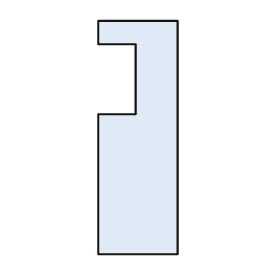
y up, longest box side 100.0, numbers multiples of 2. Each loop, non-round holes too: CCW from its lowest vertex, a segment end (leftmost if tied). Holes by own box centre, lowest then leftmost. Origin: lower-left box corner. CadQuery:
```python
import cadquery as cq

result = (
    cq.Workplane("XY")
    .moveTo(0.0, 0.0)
    .lineTo(34.0, 0.0)
    .lineTo(34.0, 100.0)
    .lineTo(0.0, 100.0)
    .lineTo(0.0, 90.0)
    .lineTo(16.0, 90.0)
    .lineTo(16.0, 60.0)
    .lineTo(0.0, 60.0)
    .close()
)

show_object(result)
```